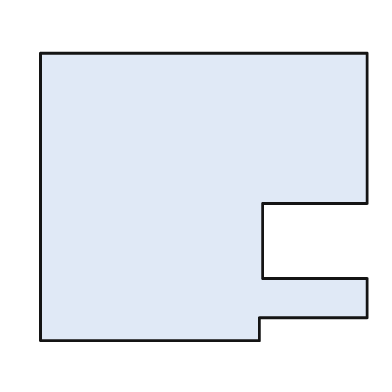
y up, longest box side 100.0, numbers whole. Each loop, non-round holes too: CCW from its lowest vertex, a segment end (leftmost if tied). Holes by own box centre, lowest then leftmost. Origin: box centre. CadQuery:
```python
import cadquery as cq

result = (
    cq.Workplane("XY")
    .moveTo(-50.0, -44.0)
    .lineTo(17.0, -44.0)
    .lineTo(17.0, -37.0)
    .lineTo(50.0, -37.0)
    .lineTo(50.0, -25.0)
    .lineTo(18.0, -25.0)
    .lineTo(18.0, -2.0)
    .lineTo(50.0, -2.0)
    .lineTo(50.0, 44.0)
    .lineTo(-50.0, 44.0)
    .close()
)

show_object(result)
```